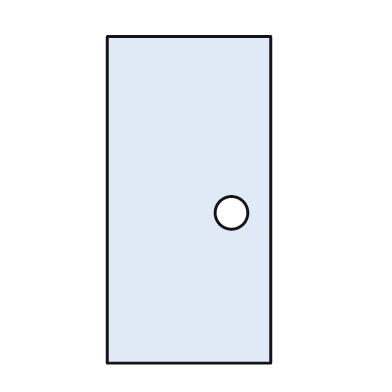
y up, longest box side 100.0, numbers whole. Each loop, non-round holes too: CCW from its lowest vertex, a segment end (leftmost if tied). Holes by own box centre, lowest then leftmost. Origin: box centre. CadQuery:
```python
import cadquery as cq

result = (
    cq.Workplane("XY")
    .moveTo(-25.0, -50.0)
    .lineTo(25.0, -50.0)
    .lineTo(25.0, 50.0)
    .lineTo(-25.0, 50.0)
    .close()
    .moveTo(13.0, -4.0)
    .circle(5.0)
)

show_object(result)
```